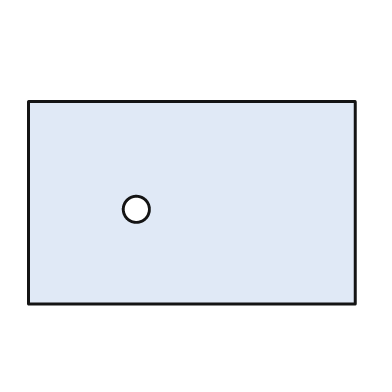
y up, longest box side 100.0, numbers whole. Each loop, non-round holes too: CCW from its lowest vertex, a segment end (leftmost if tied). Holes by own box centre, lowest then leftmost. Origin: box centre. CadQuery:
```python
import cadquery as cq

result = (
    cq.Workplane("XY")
    .moveTo(-50.0, -31.0)
    .lineTo(50.0, -31.0)
    .lineTo(50.0, 31.0)
    .lineTo(-50.0, 31.0)
    .close()
    .moveTo(-17.0, -2.0)
    .circle(4.0)
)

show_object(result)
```